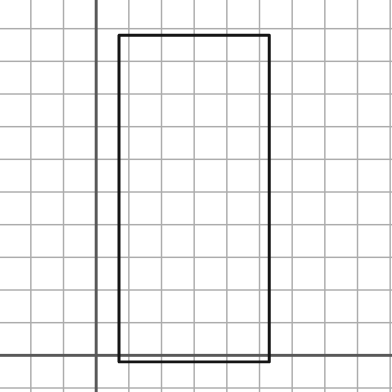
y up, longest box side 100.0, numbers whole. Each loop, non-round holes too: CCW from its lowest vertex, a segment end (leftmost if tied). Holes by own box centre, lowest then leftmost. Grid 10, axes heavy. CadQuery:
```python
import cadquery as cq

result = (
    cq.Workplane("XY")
    .moveTo(7.0, -2.0)
    .lineTo(53.0, -2.0)
    .lineTo(53.0, 98.0)
    .lineTo(7.0, 98.0)
    .close()
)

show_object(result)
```